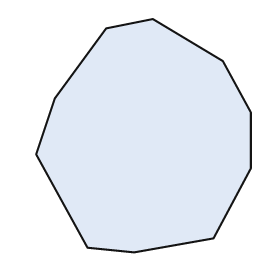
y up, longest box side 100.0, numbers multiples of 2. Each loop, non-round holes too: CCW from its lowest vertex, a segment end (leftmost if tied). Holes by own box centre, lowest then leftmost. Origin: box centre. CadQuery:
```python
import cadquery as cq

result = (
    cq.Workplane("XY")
    .moveTo(-4.0, -50.0)
    .lineTo(30.0, -44.0)
    .lineTo(46.0, -14.0)
    .lineTo(46.0, 10.0)
    .lineTo(34.0, 32.0)
    .lineTo(4.0, 50.0)
    .lineTo(-16.0, 46.0)
    .lineTo(-38.0, 16.0)
    .lineTo(-46.0, -8.0)
    .lineTo(-24.0, -48.0)
    .close()
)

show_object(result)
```